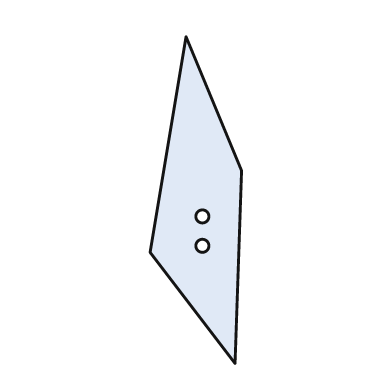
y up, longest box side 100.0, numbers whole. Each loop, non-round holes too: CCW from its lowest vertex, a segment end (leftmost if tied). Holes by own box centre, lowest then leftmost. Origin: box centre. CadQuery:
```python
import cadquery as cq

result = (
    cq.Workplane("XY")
    .moveTo(12.0, -50.0)
    .lineTo(14.0, 9.0)
    .lineTo(-3.0, 50.0)
    .lineTo(-14.0, -16.0)
    .close()
    .moveTo(2.0, -14.0)
    .circle(2.0)
    .moveTo(2.0, -5.0)
    .circle(2.0)
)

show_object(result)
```